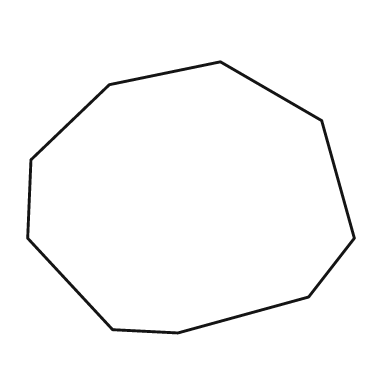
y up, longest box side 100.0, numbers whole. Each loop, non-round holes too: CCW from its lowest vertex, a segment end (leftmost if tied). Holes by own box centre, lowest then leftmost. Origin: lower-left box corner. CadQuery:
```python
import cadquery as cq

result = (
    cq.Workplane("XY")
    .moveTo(46.0, 0.0)
    .lineTo(86.0, 11.0)
    .lineTo(100.0, 29.0)
    .lineTo(90.0, 65.0)
    .lineTo(59.0, 83.0)
    .lineTo(25.0, 76.0)
    .lineTo(1.0, 53.0)
    .lineTo(0.0, 29.0)
    .lineTo(26.0, 1.0)
    .close()
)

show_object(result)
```